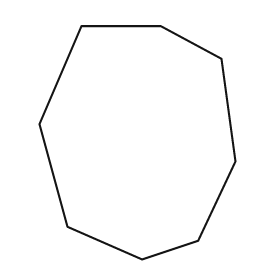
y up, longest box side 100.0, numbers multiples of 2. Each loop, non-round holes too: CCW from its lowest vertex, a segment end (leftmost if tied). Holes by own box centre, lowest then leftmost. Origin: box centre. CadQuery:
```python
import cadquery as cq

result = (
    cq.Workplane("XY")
    .moveTo(2.0, -50.0)
    .lineTo(26.0, -42.0)
    .lineTo(42.0, -8.0)
    .lineTo(36.0, 36.0)
    .lineTo(10.0, 50.0)
    .lineTo(-24.0, 50.0)
    .lineTo(-42.0, 8.0)
    .lineTo(-30.0, -36.0)
    .close()
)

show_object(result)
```